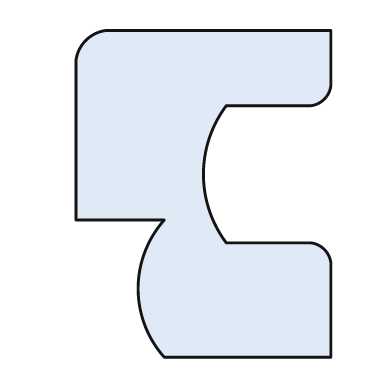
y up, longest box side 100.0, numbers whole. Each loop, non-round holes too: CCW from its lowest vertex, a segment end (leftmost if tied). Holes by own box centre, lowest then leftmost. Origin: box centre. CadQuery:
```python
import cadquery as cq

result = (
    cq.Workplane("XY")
    .moveTo(-12.0, -50.0)
    .lineTo(39.0, -50.0)
    .lineTo(39.0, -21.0)
    .threePointArc((37.0, -17.0), (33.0, -15.0))
    .lineTo(7.0, -15.0)
    .threePointArc((0.0, 6.0), (7.0, 27.0))
    .lineTo(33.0, 27.0)
    .threePointArc((37.0, 29.0), (39.0, 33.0))
    .lineTo(39.0, 50.0)
    .lineTo(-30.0, 50.0)
    .threePointArc((-36.0, 47.0), (-39.0, 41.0))
    .lineTo(-39.0, -8.0)
    .lineTo(-12.0, -8.0)
    .threePointArc((-20.0, -29.0), (-12.0, -50.0))
    .close()
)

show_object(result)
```